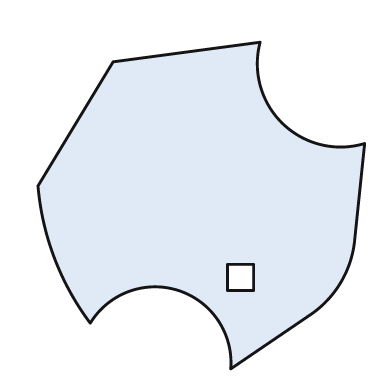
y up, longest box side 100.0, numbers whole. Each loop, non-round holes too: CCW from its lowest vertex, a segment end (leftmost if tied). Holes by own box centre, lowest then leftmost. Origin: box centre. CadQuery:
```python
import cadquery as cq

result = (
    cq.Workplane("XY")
    .moveTo(9.0, -50.0)
    .lineTo(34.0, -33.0)
    .threePointArc((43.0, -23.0), (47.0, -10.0))
    .lineTo(50.0, 19.0)
    .threePointArc((25.0, 25.0), (18.0, 50.0))
    .lineTo(-27.0, 44.0)
    .lineTo(-50.0, 6.0)
    .threePointArc((-45.0, -16.0), (-34.0, -36.0))
    .threePointArc((-7.0, -26.0), (9.0, -50.0))
    .close()
    .moveTo(8.0, -26.0)
    .lineTo(16.0, -26.0)
    .lineTo(16.0, -18.0)
    .lineTo(8.0, -18.0)
    .close()
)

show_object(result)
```